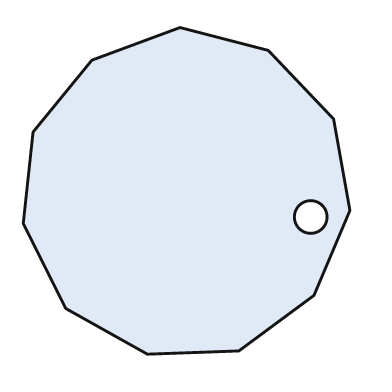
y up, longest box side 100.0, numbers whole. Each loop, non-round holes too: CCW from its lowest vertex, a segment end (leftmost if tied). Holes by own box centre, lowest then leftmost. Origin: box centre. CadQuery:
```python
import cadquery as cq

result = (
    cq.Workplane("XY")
    .moveTo(-12.0, -50.0)
    .lineTo(16.0, -49.0)
    .lineTo(39.0, -32.0)
    .lineTo(50.0, -6.0)
    .lineTo(45.0, 22.0)
    .lineTo(25.0, 43.0)
    .lineTo(-2.0, 50.0)
    .lineTo(-29.0, 40.0)
    .lineTo(-47.0, 18.0)
    .lineTo(-50.0, -10.0)
    .lineTo(-37.0, -36.0)
    .close()
    .moveTo(38.0, -8.0)
    .circle(5.0)
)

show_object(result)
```